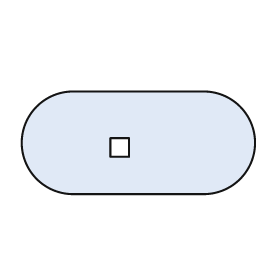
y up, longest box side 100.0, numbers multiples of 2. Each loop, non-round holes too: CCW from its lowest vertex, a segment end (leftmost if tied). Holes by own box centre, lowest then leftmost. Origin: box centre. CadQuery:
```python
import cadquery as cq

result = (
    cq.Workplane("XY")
    .moveTo(-28.0, -22.0)
    .lineTo(28.0, -22.0)
    .threePointArc((50.0, 0.0), (28.0, 22.0))
    .lineTo(-28.0, 22.0)
    .threePointArc((-50.0, 0.0), (-28.0, -22.0))
    .close()
    .moveTo(-12.0, -6.0)
    .lineTo(-4.0, -6.0)
    .lineTo(-4.0, 2.0)
    .lineTo(-12.0, 2.0)
    .close()
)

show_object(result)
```